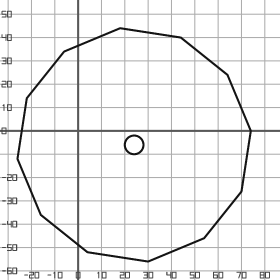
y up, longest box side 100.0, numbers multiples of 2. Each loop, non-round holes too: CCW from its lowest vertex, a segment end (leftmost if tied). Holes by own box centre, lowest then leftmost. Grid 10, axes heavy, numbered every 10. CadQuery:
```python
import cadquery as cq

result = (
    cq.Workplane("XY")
    .moveTo(30.0, -56.0)
    .lineTo(54.0, -46.0)
    .lineTo(70.0, -26.0)
    .lineTo(74.0, 0.0)
    .lineTo(64.0, 24.0)
    .lineTo(44.0, 40.0)
    .lineTo(18.0, 44.0)
    .lineTo(-6.0, 34.0)
    .lineTo(-22.0, 14.0)
    .lineTo(-26.0, -12.0)
    .lineTo(-16.0, -36.0)
    .lineTo(4.0, -52.0)
    .close()
    .moveTo(24.0, -6.0)
    .circle(4.0)
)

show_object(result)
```